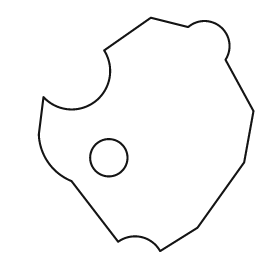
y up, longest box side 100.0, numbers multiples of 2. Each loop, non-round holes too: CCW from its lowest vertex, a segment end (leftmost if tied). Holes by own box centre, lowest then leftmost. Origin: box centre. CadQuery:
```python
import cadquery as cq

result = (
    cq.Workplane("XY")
    .moveTo(6.0, -50.0)
    .lineTo(22.0, -40.0)
    .lineTo(42.0, -12.0)
    .lineTo(46.0, 10.0)
    .lineTo(34.0, 32.0)
    .threePointArc((32.0, 46.0), (18.0, 46.0))
    .lineTo(2.0, 50.0)
    .lineTo(-18.0, 36.0)
    .threePointArc((-22.0, 14.0), (-44.0, 16.0))
    .lineTo(-46.0, 0.0)
    .threePointArc((-42.0, -12.0), (-32.0, -20.0))
    .lineTo(-12.0, -46.0)
    .threePointArc((-2.0, -44.0), (6.0, -50.0))
    .close()
    .moveTo(-16.0, -10.0)
    .circle(8.0)
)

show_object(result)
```